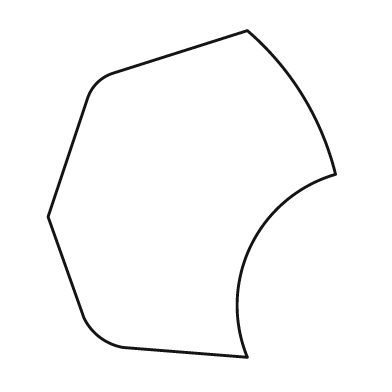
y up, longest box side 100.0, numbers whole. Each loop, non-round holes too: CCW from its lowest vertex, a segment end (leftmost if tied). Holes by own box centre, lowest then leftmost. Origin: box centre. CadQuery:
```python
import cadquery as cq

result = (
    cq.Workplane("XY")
    .moveTo(17.0, -50.0)
    .threePointArc((18.0, -16.0), (44.0, 6.0))
    .threePointArc((34.0, 30.0), (17.0, 50.0))
    .lineTo(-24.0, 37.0)
    .threePointArc((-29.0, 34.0), (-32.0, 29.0))
    .lineTo(-44.0, -7.0)
    .lineTo(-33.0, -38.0)
    .threePointArc((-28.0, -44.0), (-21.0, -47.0))
    .close()
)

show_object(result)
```